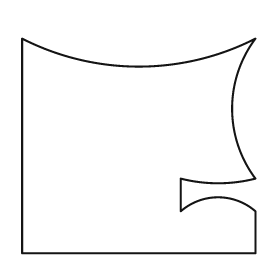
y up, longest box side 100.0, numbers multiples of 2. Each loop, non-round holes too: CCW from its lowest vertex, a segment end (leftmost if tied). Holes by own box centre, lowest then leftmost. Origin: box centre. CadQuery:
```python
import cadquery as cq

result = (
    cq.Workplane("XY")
    .moveTo(-50.0, -46.0)
    .lineTo(50.0, -46.0)
    .lineTo(50.0, -28.0)
    .threePointArc((34.0, -22.0), (18.0, -28.0))
    .lineTo(18.0, -14.0)
    .threePointArc((34.0, -16.0), (50.0, -14.0))
    .threePointArc((40.0, 16.0), (50.0, 46.0))
    .threePointArc((0.0, 34.0), (-50.0, 46.0))
    .close()
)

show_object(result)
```